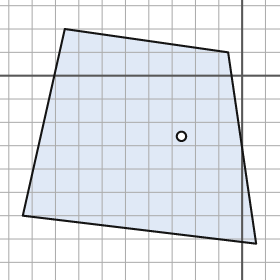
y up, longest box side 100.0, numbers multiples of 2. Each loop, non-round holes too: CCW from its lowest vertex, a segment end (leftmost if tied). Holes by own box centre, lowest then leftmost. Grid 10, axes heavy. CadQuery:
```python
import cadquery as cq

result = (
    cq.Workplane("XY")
    .moveTo(6.0, -72.0)
    .lineTo(-6.0, 10.0)
    .lineTo(-76.0, 20.0)
    .lineTo(-94.0, -60.0)
    .close()
    .moveTo(-26.0, -26.0)
    .circle(2.0)
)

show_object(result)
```